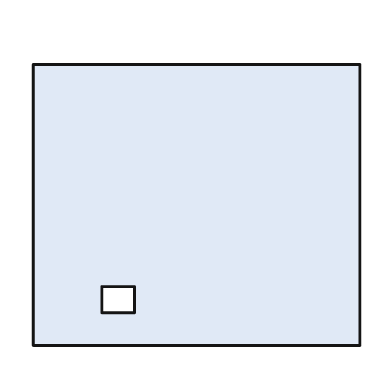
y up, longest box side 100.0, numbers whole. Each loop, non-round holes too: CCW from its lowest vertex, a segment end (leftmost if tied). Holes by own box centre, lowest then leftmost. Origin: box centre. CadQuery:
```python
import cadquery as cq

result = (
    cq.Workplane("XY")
    .moveTo(-50.0, -43.0)
    .lineTo(50.0, -43.0)
    .lineTo(50.0, 43.0)
    .lineTo(-50.0, 43.0)
    .close()
    .moveTo(-29.0, -33.0)
    .lineTo(-19.0, -33.0)
    .lineTo(-19.0, -25.0)
    .lineTo(-29.0, -25.0)
    .close()
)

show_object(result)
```